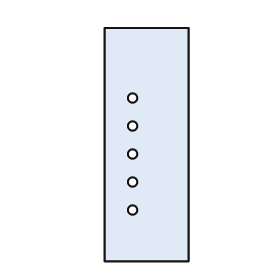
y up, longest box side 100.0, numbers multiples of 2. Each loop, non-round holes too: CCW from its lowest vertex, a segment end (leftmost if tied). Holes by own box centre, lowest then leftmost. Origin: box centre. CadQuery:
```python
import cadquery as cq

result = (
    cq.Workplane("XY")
    .moveTo(-18.0, -50.0)
    .lineTo(18.0, -50.0)
    .lineTo(18.0, 50.0)
    .lineTo(-18.0, 50.0)
    .close()
    .moveTo(-6.0, -28.0)
    .circle(2.0)
    .moveTo(-6.0, -16.0)
    .circle(2.0)
    .moveTo(-6.0, -4.0)
    .circle(2.0)
    .moveTo(-6.0, 8.0)
    .circle(2.0)
    .moveTo(-6.0, 20.0)
    .circle(2.0)
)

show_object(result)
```